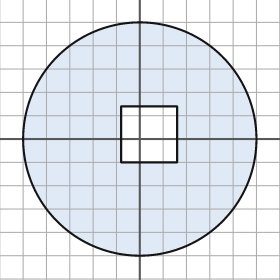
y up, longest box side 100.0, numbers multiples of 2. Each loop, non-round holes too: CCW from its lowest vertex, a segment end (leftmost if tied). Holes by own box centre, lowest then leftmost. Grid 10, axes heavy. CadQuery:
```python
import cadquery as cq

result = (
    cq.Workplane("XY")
    .moveTo(0.0, 0.0)
    .circle(50.0)
    .moveTo(-8.0, -10.0)
    .lineTo(16.0, -10.0)
    .lineTo(16.0, 14.0)
    .lineTo(-8.0, 14.0)
    .close()
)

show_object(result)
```